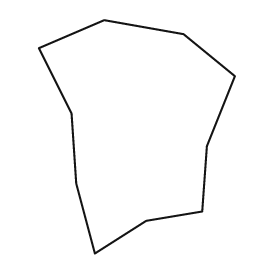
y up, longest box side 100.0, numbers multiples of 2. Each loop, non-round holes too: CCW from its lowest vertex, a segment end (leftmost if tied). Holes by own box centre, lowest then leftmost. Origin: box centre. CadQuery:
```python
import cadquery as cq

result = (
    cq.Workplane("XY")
    .moveTo(-18.0, -50.0)
    .lineTo(4.0, -36.0)
    .lineTo(28.0, -32.0)
    .lineTo(30.0, -4.0)
    .lineTo(42.0, 26.0)
    .lineTo(20.0, 44.0)
    .lineTo(-14.0, 50.0)
    .lineTo(-42.0, 38.0)
    .lineTo(-28.0, 10.0)
    .lineTo(-26.0, -20.0)
    .close()
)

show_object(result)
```